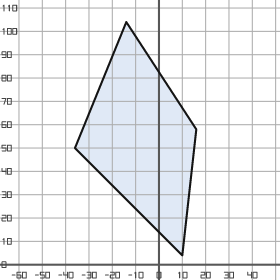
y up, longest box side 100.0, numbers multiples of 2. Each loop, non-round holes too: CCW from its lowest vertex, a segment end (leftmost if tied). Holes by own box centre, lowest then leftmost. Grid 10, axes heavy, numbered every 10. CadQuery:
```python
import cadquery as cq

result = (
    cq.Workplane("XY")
    .moveTo(10.0, 4.0)
    .lineTo(16.0, 58.0)
    .lineTo(-14.0, 104.0)
    .lineTo(-36.0, 50.0)
    .close()
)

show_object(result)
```